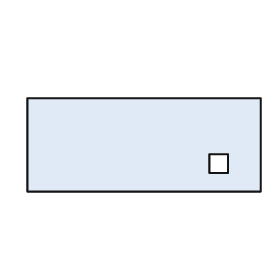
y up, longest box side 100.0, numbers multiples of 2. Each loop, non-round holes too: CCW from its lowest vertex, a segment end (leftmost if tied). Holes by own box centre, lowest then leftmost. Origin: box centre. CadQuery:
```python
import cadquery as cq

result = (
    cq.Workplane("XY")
    .moveTo(-50.0, -20.0)
    .lineTo(50.0, -20.0)
    .lineTo(50.0, 20.0)
    .lineTo(-50.0, 20.0)
    .close()
    .moveTo(28.0, -12.0)
    .lineTo(36.0, -12.0)
    .lineTo(36.0, -4.0)
    .lineTo(28.0, -4.0)
    .close()
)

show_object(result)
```